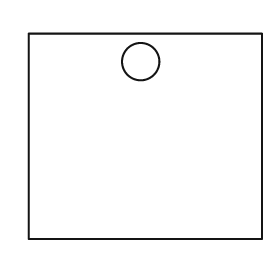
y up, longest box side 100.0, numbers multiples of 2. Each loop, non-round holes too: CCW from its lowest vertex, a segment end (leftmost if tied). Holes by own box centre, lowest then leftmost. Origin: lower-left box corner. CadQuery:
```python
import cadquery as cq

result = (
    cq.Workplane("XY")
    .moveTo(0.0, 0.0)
    .lineTo(100.0, 0.0)
    .lineTo(100.0, 88.0)
    .lineTo(0.0, 88.0)
    .close()
    .moveTo(48.0, 76.0)
    .circle(8.0)
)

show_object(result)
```